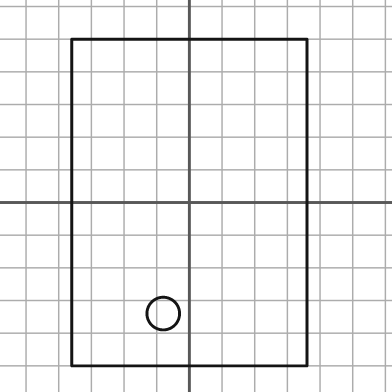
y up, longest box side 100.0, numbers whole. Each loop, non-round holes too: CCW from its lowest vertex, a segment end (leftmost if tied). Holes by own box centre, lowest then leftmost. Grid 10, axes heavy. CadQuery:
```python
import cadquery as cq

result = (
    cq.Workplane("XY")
    .moveTo(-36.0, -50.0)
    .lineTo(36.0, -50.0)
    .lineTo(36.0, 50.0)
    .lineTo(-36.0, 50.0)
    .close()
    .moveTo(-8.0, -34.0)
    .circle(5.0)
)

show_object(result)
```